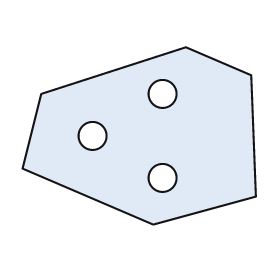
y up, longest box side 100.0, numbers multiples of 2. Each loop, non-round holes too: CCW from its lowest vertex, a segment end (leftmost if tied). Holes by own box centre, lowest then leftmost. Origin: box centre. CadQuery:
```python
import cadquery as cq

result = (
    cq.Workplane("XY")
    .moveTo(6.0, -38.0)
    .lineTo(50.0, -26.0)
    .lineTo(48.0, 26.0)
    .lineTo(20.0, 38.0)
    .lineTo(-42.0, 18.0)
    .lineTo(-50.0, -14.0)
    .close()
    .moveTo(10.0, -18.0)
    .circle(6.0)
    .moveTo(-20.0, 0.0)
    .circle(6.0)
    .moveTo(10.0, 18.0)
    .circle(6.0)
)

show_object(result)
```